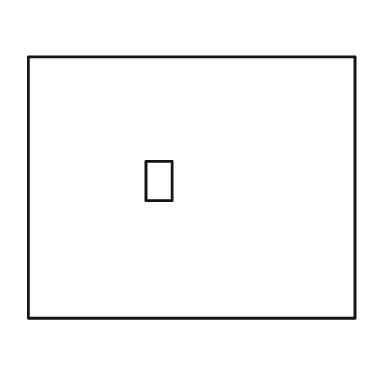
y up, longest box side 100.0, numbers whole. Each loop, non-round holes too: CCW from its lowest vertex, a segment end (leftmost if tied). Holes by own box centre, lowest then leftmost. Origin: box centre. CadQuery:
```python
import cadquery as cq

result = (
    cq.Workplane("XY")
    .moveTo(-50.0, -40.0)
    .lineTo(50.0, -40.0)
    .lineTo(50.0, 40.0)
    .lineTo(-50.0, 40.0)
    .close()
    .moveTo(-14.0, -4.0)
    .lineTo(-6.0, -4.0)
    .lineTo(-6.0, 8.0)
    .lineTo(-14.0, 8.0)
    .close()
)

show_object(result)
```